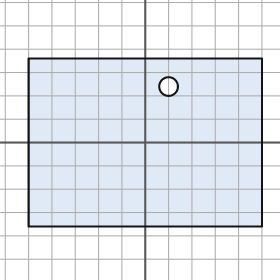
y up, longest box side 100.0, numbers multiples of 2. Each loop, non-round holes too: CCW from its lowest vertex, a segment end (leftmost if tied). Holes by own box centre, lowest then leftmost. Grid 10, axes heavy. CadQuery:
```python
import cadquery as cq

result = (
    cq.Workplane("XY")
    .moveTo(-50.0, -36.0)
    .lineTo(50.0, -36.0)
    .lineTo(50.0, 36.0)
    .lineTo(-50.0, 36.0)
    .close()
    .moveTo(10.0, 24.0)
    .circle(4.0)
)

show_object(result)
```